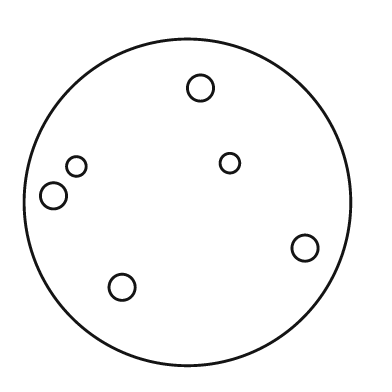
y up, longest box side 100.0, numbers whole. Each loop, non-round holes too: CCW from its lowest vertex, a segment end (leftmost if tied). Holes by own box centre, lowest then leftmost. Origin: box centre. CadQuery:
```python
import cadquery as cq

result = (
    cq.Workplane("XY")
    .moveTo(0.0, 0.0)
    .circle(50.0)
    .moveTo(-20.0, -26.0)
    .circle(4.0)
    .moveTo(36.0, -14.0)
    .circle(4.0)
    .moveTo(-41.0, 2.0)
    .circle(4.0)
    .moveTo(-34.0, 11.0)
    .circle(3.0)
    .moveTo(13.0, 12.0)
    .circle(3.0)
    .moveTo(4.0, 35.0)
    .circle(4.0)
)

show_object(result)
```